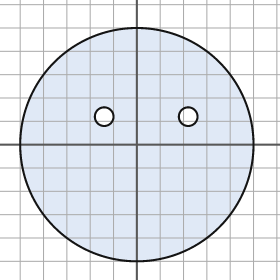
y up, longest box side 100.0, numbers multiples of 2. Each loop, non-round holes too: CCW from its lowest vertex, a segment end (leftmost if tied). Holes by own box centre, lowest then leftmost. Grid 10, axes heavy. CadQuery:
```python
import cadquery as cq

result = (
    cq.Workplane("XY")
    .moveTo(0.0, 0.0)
    .circle(50.0)
    .moveTo(-14.0, 12.0)
    .circle(4.0)
    .moveTo(22.0, 12.0)
    .circle(4.0)
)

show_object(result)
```